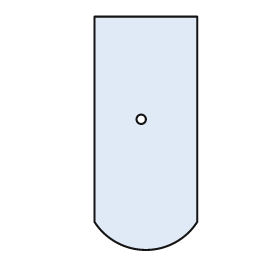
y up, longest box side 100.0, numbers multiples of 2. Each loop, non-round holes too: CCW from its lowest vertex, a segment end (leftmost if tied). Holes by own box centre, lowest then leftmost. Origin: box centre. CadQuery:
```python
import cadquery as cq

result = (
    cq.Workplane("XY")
    .moveTo(-22.0, -38.0)
    .threePointArc((0.0, -50.0), (22.0, -38.0))
    .lineTo(22.0, 50.0)
    .lineTo(-22.0, 50.0)
    .close()
    .moveTo(-2.0, 6.0)
    .circle(2.0)
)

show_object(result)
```